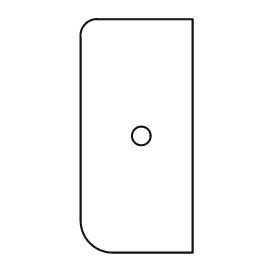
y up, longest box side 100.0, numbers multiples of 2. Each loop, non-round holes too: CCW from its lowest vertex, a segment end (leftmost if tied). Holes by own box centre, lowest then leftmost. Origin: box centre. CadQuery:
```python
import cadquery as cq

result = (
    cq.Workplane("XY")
    .moveTo(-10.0, -50.0)
    .lineTo(24.0, -50.0)
    .lineTo(24.0, 50.0)
    .lineTo(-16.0, 50.0)
    .threePointArc((-22.0, 48.0), (-24.0, 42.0))
    .lineTo(-24.0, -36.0)
    .threePointArc((-20.0, -46.0), (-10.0, -50.0))
    .close()
    .moveTo(2.0, 0.0)
    .circle(4.0)
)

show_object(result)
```